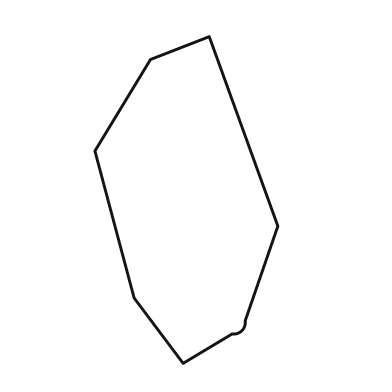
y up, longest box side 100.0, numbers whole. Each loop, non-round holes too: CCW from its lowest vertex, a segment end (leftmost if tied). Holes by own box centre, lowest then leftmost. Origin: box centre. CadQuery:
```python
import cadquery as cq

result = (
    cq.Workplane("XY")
    .moveTo(-1.0, -50.0)
    .lineTo(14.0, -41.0)
    .threePointArc((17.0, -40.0), (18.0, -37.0))
    .lineTo(28.0, -8.0)
    .lineTo(7.0, 50.0)
    .lineTo(-11.0, 43.0)
    .lineTo(-28.0, 15.0)
    .lineTo(-16.0, -30.0)
    .close()
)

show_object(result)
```